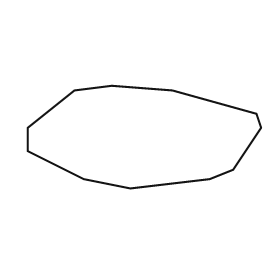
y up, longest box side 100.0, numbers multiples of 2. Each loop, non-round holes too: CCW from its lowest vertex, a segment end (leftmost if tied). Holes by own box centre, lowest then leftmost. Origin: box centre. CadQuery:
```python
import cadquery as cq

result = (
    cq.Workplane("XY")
    .moveTo(-6.0, -22.0)
    .lineTo(28.0, -18.0)
    .lineTo(38.0, -14.0)
    .lineTo(50.0, 4.0)
    .lineTo(48.0, 10.0)
    .lineTo(12.0, 20.0)
    .lineTo(-14.0, 22.0)
    .lineTo(-30.0, 20.0)
    .lineTo(-50.0, 4.0)
    .lineTo(-50.0, -6.0)
    .lineTo(-26.0, -18.0)
    .close()
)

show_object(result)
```